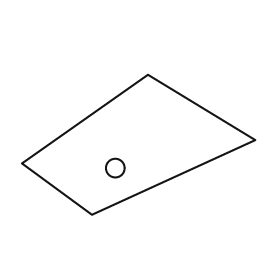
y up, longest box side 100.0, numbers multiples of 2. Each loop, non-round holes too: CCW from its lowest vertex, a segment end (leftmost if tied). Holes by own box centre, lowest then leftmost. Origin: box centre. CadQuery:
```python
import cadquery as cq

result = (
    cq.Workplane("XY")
    .moveTo(-20.0, -30.0)
    .lineTo(50.0, 2.0)
    .lineTo(4.0, 30.0)
    .lineTo(-50.0, -8.0)
    .close()
    .moveTo(-10.0, -10.0)
    .circle(4.0)
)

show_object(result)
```